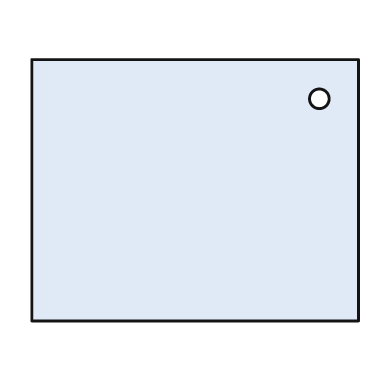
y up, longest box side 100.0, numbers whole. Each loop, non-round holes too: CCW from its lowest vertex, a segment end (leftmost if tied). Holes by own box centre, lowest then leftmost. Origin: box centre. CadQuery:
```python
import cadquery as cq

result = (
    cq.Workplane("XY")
    .moveTo(-50.0, -40.0)
    .lineTo(50.0, -40.0)
    .lineTo(50.0, 40.0)
    .lineTo(-50.0, 40.0)
    .close()
    .moveTo(38.0, 28.0)
    .circle(3.0)
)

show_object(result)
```